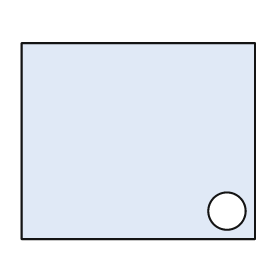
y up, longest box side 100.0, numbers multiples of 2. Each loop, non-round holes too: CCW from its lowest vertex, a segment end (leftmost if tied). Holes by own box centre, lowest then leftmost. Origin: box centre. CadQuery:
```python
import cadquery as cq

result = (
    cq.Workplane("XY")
    .moveTo(-50.0, -42.0)
    .lineTo(50.0, -42.0)
    .lineTo(50.0, 42.0)
    .lineTo(-50.0, 42.0)
    .close()
    .moveTo(38.0, -30.0)
    .circle(8.0)
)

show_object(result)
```